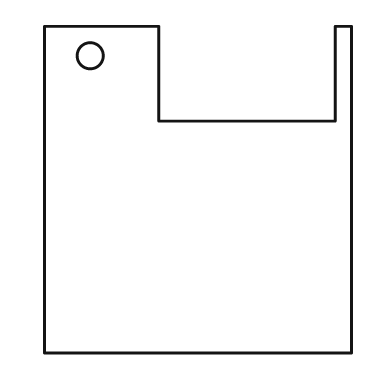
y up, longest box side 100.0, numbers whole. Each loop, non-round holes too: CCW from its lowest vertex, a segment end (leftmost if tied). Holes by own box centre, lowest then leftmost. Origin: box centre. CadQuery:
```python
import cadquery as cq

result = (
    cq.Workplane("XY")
    .moveTo(-47.0, -50.0)
    .lineTo(47.0, -50.0)
    .lineTo(47.0, 50.0)
    .lineTo(42.0, 50.0)
    .lineTo(42.0, 21.0)
    .lineTo(-12.0, 21.0)
    .lineTo(-12.0, 50.0)
    .lineTo(-47.0, 50.0)
    .close()
    .moveTo(-33.0, 41.0)
    .circle(4.0)
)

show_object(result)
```